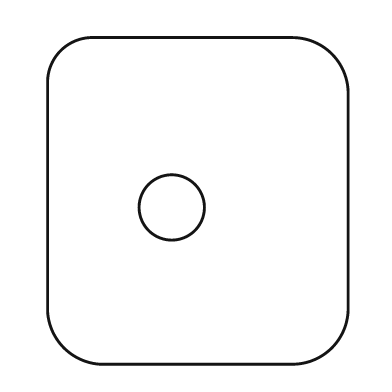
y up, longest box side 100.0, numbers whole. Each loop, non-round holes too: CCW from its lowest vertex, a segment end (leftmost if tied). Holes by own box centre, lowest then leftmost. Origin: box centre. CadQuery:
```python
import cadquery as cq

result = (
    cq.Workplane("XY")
    .moveTo(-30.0, -50.0)
    .lineTo(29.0, -50.0)
    .threePointArc((41.0, -45.0), (46.0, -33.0))
    .lineTo(46.0, 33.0)
    .threePointArc((41.0, 45.0), (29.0, 50.0))
    .lineTo(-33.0, 50.0)
    .threePointArc((-42.0, 46.0), (-46.0, 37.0))
    .lineTo(-46.0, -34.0)
    .threePointArc((-41.0, -45.0), (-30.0, -50.0))
    .close()
    .moveTo(-8.0, -2.0)
    .circle(10.0)
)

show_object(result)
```